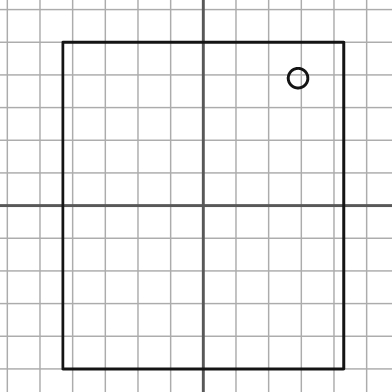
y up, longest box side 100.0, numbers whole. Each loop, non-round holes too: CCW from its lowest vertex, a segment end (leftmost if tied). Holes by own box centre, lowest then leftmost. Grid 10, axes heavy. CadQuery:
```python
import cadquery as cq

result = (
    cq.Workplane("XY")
    .moveTo(-43.0, -50.0)
    .lineTo(43.0, -50.0)
    .lineTo(43.0, 50.0)
    .lineTo(-43.0, 50.0)
    .close()
    .moveTo(29.0, 39.0)
    .circle(3.0)
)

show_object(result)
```